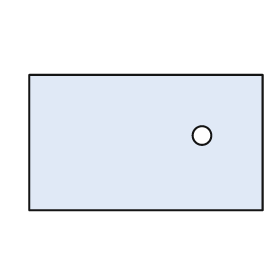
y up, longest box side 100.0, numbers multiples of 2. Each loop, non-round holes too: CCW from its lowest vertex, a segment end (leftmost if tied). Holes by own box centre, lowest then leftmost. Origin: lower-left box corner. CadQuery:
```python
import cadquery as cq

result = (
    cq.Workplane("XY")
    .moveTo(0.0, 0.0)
    .lineTo(100.0, 0.0)
    .lineTo(100.0, 58.0)
    .lineTo(0.0, 58.0)
    .close()
    .moveTo(74.0, 32.0)
    .circle(4.0)
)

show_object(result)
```